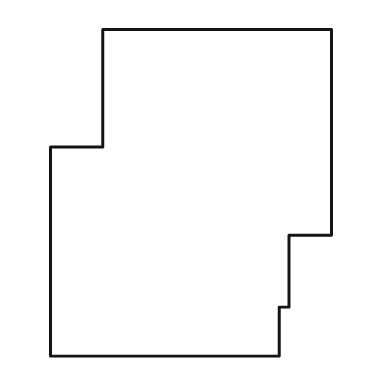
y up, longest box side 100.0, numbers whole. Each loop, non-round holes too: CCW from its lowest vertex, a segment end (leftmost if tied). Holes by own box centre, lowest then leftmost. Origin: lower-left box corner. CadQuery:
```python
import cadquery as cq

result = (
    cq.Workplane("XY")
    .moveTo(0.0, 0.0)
    .lineTo(70.0, 0.0)
    .lineTo(70.0, 15.0)
    .lineTo(73.0, 15.0)
    .lineTo(73.0, 37.0)
    .lineTo(86.0, 37.0)
    .lineTo(86.0, 100.0)
    .lineTo(16.0, 100.0)
    .lineTo(16.0, 64.0)
    .lineTo(0.0, 64.0)
    .close()
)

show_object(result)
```